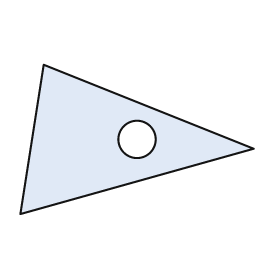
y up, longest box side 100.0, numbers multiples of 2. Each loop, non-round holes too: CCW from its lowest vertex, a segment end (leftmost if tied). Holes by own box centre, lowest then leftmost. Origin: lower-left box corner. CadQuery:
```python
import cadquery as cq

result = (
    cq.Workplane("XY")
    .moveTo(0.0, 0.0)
    .lineTo(100.0, 28.0)
    .lineTo(10.0, 64.0)
    .close()
    .moveTo(50.0, 32.0)
    .circle(8.0)
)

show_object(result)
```